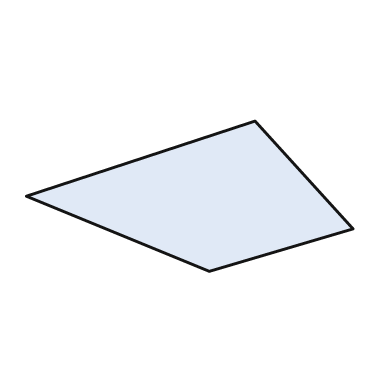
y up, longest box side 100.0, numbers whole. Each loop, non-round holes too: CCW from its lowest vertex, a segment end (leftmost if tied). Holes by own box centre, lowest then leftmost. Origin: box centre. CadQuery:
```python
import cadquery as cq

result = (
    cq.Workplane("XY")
    .moveTo(6.0, -23.0)
    .lineTo(50.0, -10.0)
    .lineTo(20.0, 23.0)
    .lineTo(-50.0, 0.0)
    .close()
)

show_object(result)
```